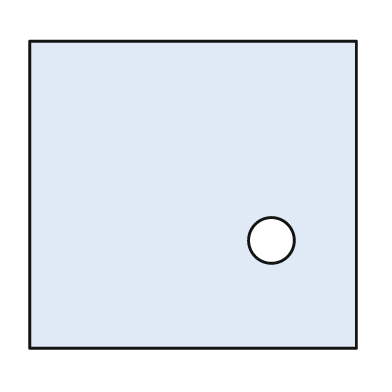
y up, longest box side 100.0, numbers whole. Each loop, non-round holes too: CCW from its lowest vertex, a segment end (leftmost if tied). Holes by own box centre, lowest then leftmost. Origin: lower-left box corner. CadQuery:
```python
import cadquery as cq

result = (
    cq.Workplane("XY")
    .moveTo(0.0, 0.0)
    .lineTo(100.0, 0.0)
    .lineTo(100.0, 94.0)
    .lineTo(0.0, 94.0)
    .close()
    .moveTo(74.0, 33.0)
    .circle(7.0)
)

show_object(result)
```